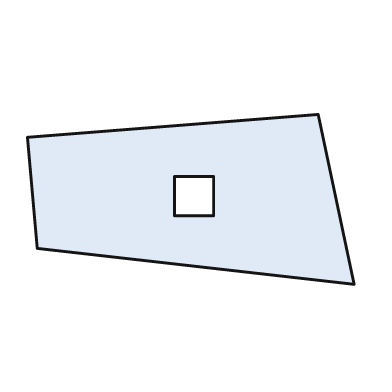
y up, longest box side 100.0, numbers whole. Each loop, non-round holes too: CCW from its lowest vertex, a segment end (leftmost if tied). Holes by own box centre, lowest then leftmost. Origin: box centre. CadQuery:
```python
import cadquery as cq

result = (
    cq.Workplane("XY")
    .moveTo(50.0, -26.0)
    .lineTo(39.0, 26.0)
    .lineTo(-50.0, 19.0)
    .lineTo(-47.0, -15.0)
    .close()
    .moveTo(-5.0, -5.0)
    .lineTo(7.0, -5.0)
    .lineTo(7.0, 7.0)
    .lineTo(-5.0, 7.0)
    .close()
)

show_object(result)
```